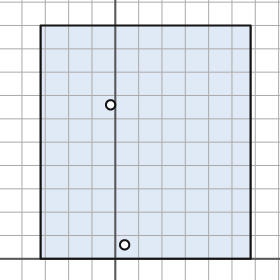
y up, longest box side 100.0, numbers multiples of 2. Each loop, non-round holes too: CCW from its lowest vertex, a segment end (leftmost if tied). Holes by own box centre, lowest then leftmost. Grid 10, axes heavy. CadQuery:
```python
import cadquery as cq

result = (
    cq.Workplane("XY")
    .moveTo(-32.0, 0.0)
    .lineTo(58.0, 0.0)
    .lineTo(58.0, 100.0)
    .lineTo(-32.0, 100.0)
    .close()
    .moveTo(4.0, 6.0)
    .circle(2.0)
    .moveTo(-2.0, 66.0)
    .circle(2.0)
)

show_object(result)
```